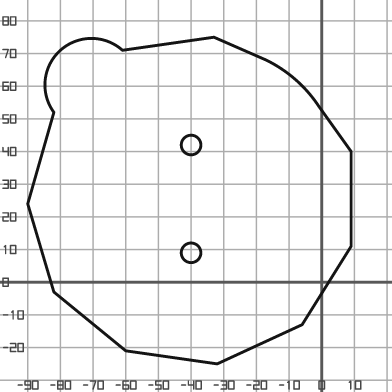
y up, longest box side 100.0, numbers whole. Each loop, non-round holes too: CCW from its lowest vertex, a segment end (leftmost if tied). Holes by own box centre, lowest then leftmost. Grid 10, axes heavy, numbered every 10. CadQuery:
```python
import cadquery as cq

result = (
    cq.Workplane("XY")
    .moveTo(-32.0, -25.0)
    .lineTo(-6.0, -13.0)
    .lineTo(9.0, 11.0)
    .lineTo(9.0, 40.0)
    .lineTo(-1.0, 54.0)
    .threePointArc((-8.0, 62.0), (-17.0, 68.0))
    .lineTo(-33.0, 75.0)
    .lineTo(-61.0, 71.0)
    .threePointArc((-80.0, 71.0), (-82.0, 52.0))
    .lineTo(-90.0, 24.0)
    .lineTo(-82.0, -3.0)
    .lineTo(-60.0, -21.0)
    .close()
    .moveTo(-40.0, 9.0)
    .circle(3.0)
    .moveTo(-40.0, 42.0)
    .circle(3.0)
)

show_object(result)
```